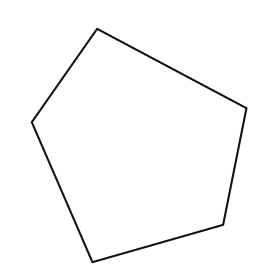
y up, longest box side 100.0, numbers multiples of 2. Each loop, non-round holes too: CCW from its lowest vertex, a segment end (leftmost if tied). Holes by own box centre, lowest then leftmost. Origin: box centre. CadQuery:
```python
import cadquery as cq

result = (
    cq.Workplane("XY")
    .moveTo(-20.0, -50.0)
    .lineTo(36.0, -34.0)
    .lineTo(46.0, 16.0)
    .lineTo(-18.0, 50.0)
    .lineTo(-46.0, 10.0)
    .close()
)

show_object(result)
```